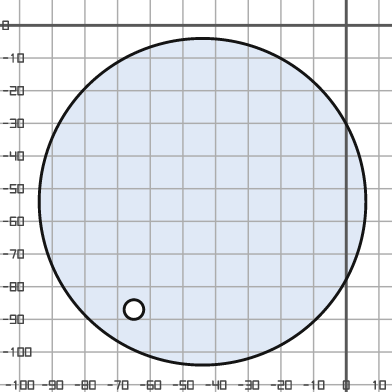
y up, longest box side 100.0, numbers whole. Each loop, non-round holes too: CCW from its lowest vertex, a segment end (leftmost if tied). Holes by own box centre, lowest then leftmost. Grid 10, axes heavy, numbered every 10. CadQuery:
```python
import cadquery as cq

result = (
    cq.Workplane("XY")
    .moveTo(-44.0, -54.0)
    .circle(50.0)
    .moveTo(-65.0, -87.0)
    .circle(3.0)
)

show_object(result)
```